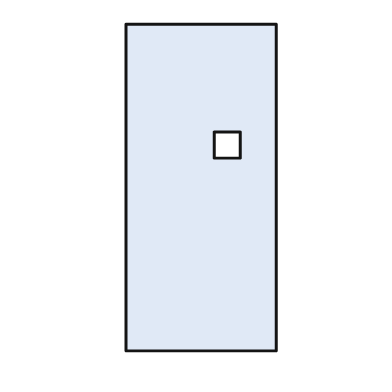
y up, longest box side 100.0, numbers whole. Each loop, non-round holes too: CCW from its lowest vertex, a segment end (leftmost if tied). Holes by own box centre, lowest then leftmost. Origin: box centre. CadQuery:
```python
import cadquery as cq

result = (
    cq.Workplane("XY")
    .moveTo(-23.0, -50.0)
    .lineTo(23.0, -50.0)
    .lineTo(23.0, 50.0)
    .lineTo(-23.0, 50.0)
    .close()
    .moveTo(4.0, 9.0)
    .lineTo(12.0, 9.0)
    .lineTo(12.0, 17.0)
    .lineTo(4.0, 17.0)
    .close()
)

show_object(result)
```